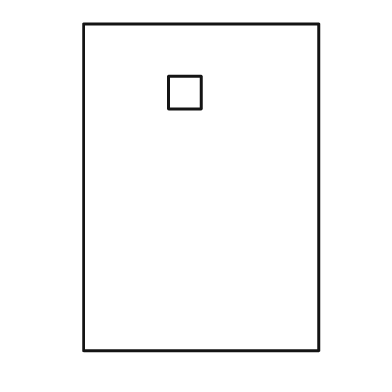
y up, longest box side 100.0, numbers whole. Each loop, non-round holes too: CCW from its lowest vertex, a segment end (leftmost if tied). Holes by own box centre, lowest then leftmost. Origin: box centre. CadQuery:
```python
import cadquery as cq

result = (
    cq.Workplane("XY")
    .moveTo(-36.0, -50.0)
    .lineTo(36.0, -50.0)
    .lineTo(36.0, 50.0)
    .lineTo(-36.0, 50.0)
    .close()
    .moveTo(-10.0, 24.0)
    .lineTo(0.0, 24.0)
    .lineTo(0.0, 34.0)
    .lineTo(-10.0, 34.0)
    .close()
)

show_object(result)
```